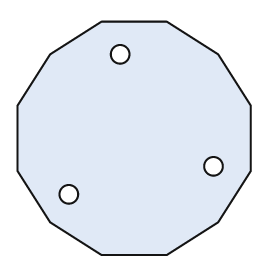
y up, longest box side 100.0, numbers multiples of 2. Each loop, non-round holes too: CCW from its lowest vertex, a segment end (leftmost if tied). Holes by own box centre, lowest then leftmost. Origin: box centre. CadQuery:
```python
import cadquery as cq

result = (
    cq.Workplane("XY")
    .moveTo(-14.0, -50.0)
    .lineTo(14.0, -50.0)
    .lineTo(36.0, -36.0)
    .lineTo(50.0, -14.0)
    .lineTo(50.0, 14.0)
    .lineTo(36.0, 36.0)
    .lineTo(14.0, 50.0)
    .lineTo(-14.0, 50.0)
    .lineTo(-36.0, 36.0)
    .lineTo(-50.0, 14.0)
    .lineTo(-50.0, -14.0)
    .lineTo(-36.0, -36.0)
    .close()
    .moveTo(-28.0, -24.0)
    .circle(4.0)
    .moveTo(34.0, -12.0)
    .circle(4.0)
    .moveTo(-6.0, 36.0)
    .circle(4.0)
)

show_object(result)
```